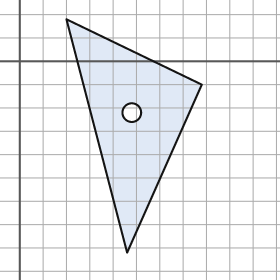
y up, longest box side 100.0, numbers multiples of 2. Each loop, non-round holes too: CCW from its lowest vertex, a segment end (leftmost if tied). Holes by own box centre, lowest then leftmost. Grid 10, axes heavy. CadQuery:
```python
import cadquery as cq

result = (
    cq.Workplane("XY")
    .moveTo(46.0, -82.0)
    .lineTo(78.0, -10.0)
    .lineTo(20.0, 18.0)
    .close()
    .moveTo(48.0, -22.0)
    .circle(4.0)
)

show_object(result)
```